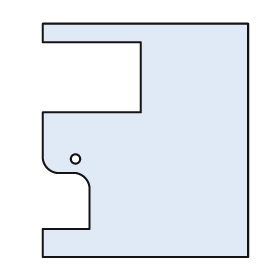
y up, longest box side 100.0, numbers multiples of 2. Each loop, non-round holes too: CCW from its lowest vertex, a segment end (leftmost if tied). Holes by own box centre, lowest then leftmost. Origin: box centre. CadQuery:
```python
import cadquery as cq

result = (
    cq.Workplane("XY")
    .moveTo(-44.0, -50.0)
    .lineTo(44.0, -50.0)
    .lineTo(44.0, 50.0)
    .lineTo(-44.0, 50.0)
    .lineTo(-44.0, 42.0)
    .lineTo(-2.0, 42.0)
    .lineTo(-2.0, 12.0)
    .lineTo(-44.0, 12.0)
    .lineTo(-44.0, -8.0)
    .threePointArc((-42.0, -12.0), (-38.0, -14.0))
    .lineTo(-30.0, -14.0)
    .threePointArc((-26.0, -16.0), (-24.0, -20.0))
    .lineTo(-24.0, -38.0)
    .lineTo(-44.0, -38.0)
    .close()
    .moveTo(-30.0, -8.0)
    .circle(2.0)
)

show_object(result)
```